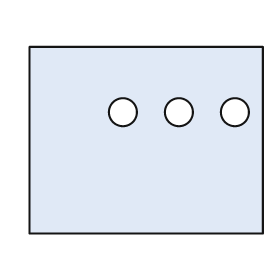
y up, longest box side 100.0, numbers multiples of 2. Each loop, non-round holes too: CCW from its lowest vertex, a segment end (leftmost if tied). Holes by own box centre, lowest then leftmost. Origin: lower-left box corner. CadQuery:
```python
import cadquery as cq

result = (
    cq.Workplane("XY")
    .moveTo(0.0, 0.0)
    .lineTo(100.0, 0.0)
    .lineTo(100.0, 80.0)
    .lineTo(0.0, 80.0)
    .close()
    .moveTo(40.0, 52.0)
    .circle(6.0)
    .moveTo(64.0, 52.0)
    .circle(6.0)
    .moveTo(88.0, 52.0)
    .circle(6.0)
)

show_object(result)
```